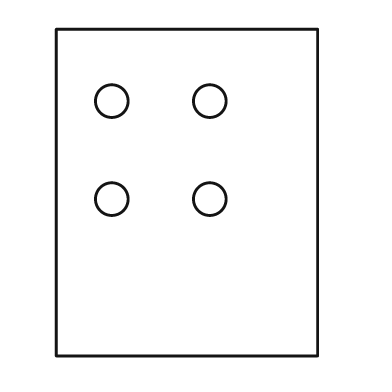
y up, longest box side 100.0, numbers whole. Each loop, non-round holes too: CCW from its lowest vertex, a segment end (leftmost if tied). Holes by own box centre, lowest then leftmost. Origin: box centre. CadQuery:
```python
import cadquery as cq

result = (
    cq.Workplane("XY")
    .moveTo(-40.0, -50.0)
    .lineTo(40.0, -50.0)
    .lineTo(40.0, 50.0)
    .lineTo(-40.0, 50.0)
    .close()
    .moveTo(-23.0, -2.0)
    .circle(5.0)
    .moveTo(7.0, -2.0)
    .circle(5.0)
    .moveTo(-23.0, 28.0)
    .circle(5.0)
    .moveTo(7.0, 28.0)
    .circle(5.0)
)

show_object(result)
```